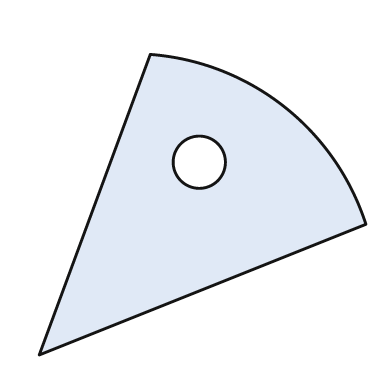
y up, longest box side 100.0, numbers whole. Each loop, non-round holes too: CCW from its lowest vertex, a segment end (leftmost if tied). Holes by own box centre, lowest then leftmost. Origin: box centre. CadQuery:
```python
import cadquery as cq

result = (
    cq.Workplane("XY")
    .moveTo(-50.0, -46.0)
    .lineTo(50.0, -6.0)
    .threePointArc((25.0, 30.0), (-16.0, 46.0))
    .close()
    .moveTo(-1.0, 13.0)
    .circle(8.0)
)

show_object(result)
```